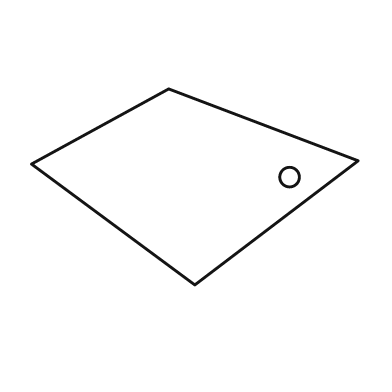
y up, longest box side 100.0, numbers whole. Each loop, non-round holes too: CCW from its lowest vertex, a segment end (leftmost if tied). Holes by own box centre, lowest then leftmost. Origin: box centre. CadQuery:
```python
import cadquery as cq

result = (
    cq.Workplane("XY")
    .moveTo(0.0, -30.0)
    .lineTo(50.0, 8.0)
    .lineTo(-8.0, 30.0)
    .lineTo(-50.0, 7.0)
    .close()
    .moveTo(29.0, 3.0)
    .circle(3.0)
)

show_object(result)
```